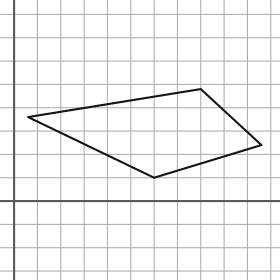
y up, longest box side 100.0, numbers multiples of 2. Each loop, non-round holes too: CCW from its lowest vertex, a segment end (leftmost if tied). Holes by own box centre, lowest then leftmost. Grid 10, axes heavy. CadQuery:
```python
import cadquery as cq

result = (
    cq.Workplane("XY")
    .moveTo(60.0, 10.0)
    .lineTo(106.0, 24.0)
    .lineTo(80.0, 48.0)
    .lineTo(6.0, 36.0)
    .close()
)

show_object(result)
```